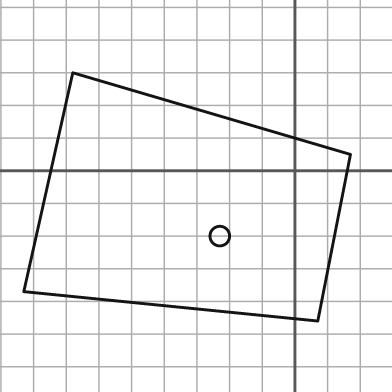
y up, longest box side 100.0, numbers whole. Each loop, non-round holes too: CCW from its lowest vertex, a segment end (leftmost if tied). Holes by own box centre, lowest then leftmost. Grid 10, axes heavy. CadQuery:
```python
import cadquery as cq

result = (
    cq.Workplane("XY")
    .moveTo(7.0, -46.0)
    .lineTo(17.0, 5.0)
    .lineTo(-68.0, 30.0)
    .lineTo(-83.0, -37.0)
    .close()
    .moveTo(-23.0, -20.0)
    .circle(3.0)
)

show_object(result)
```